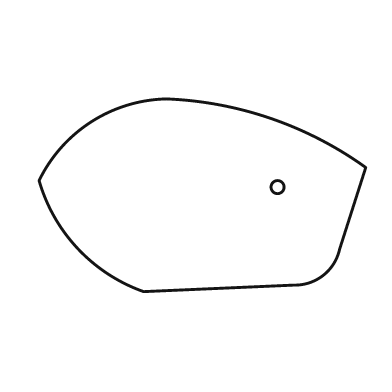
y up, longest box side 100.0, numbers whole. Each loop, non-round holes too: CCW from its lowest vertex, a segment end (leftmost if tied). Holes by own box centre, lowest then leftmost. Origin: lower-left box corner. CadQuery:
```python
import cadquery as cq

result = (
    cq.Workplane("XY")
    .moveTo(32.0, 0.0)
    .lineTo(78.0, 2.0)
    .threePointArc((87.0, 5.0), (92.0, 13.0))
    .lineTo(100.0, 38.0)
    .threePointArc((71.0, 53.0), (39.0, 59.0))
    .threePointArc((16.0, 52.0), (0.0, 34.0))
    .threePointArc((12.0, 13.0), (32.0, 0.0))
    .close()
    .moveTo(73.0, 32.0)
    .circle(2.0)
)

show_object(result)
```